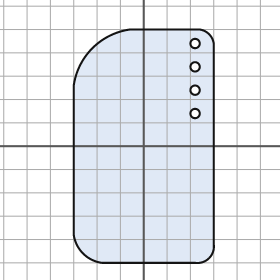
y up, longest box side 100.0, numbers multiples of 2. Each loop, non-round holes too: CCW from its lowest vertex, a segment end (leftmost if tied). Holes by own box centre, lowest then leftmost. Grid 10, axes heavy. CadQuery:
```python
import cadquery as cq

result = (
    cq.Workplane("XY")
    .moveTo(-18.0, -50.0)
    .lineTo(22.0, -50.0)
    .threePointArc((28.0, -48.0), (30.0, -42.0))
    .lineTo(30.0, 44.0)
    .threePointArc((28.0, 48.0), (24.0, 50.0))
    .lineTo(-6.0, 50.0)
    .threePointArc((-22.0, 42.0), (-30.0, 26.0))
    .lineTo(-30.0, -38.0)
    .threePointArc((-26.0, -46.0), (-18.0, -50.0))
    .close()
    .moveTo(22.0, 14.0)
    .circle(2.0)
    .moveTo(22.0, 24.0)
    .circle(2.0)
    .moveTo(22.0, 34.0)
    .circle(2.0)
    .moveTo(22.0, 44.0)
    .circle(2.0)
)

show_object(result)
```